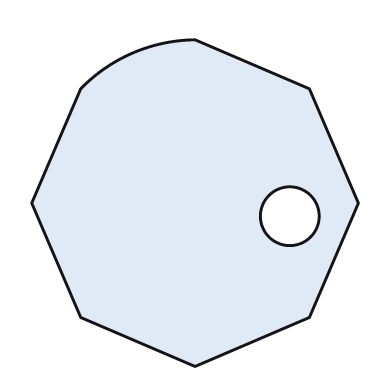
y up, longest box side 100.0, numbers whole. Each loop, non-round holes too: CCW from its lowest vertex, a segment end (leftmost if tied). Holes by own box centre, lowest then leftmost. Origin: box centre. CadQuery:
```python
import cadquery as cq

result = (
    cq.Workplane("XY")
    .moveTo(0.0, -50.0)
    .lineTo(35.0, -35.0)
    .lineTo(50.0, 0.0)
    .lineTo(35.0, 35.0)
    .lineTo(0.0, 50.0)
    .threePointArc((-19.0, 46.0), (-35.0, 35.0))
    .lineTo(-50.0, 0.0)
    .lineTo(-35.0, -35.0)
    .close()
    .moveTo(29.0, -4.0)
    .circle(9.0)
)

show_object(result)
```